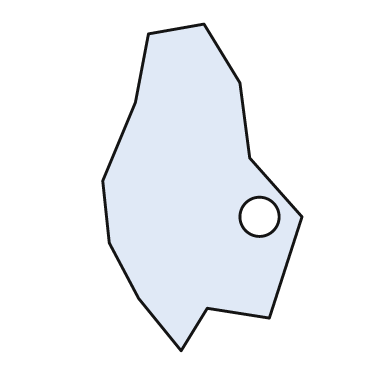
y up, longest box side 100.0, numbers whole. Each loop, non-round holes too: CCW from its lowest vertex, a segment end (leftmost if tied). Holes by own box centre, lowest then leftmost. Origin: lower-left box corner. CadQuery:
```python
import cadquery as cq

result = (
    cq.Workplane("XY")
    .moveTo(24.0, 0.0)
    .lineTo(32.0, 13.0)
    .lineTo(51.0, 10.0)
    .lineTo(61.0, 41.0)
    .lineTo(45.0, 59.0)
    .lineTo(42.0, 82.0)
    .lineTo(31.0, 100.0)
    .lineTo(14.0, 97.0)
    .lineTo(10.0, 76.0)
    .lineTo(0.0, 52.0)
    .lineTo(2.0, 33.0)
    .lineTo(11.0, 16.0)
    .close()
    .moveTo(48.0, 41.0)
    .circle(6.0)
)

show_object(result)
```